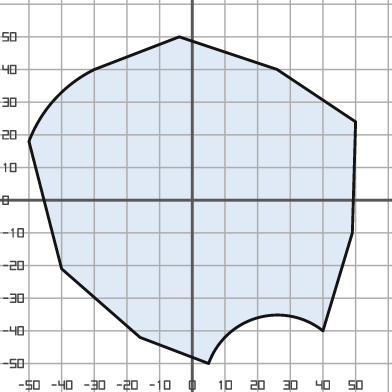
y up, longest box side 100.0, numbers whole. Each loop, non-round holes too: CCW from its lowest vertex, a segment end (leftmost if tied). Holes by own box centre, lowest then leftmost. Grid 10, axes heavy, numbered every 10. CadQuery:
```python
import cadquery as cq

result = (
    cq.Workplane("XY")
    .moveTo(5.0, -50.0)
    .threePointArc((20.0, -36.0), (40.0, -40.0))
    .lineTo(49.0, -10.0)
    .lineTo(50.0, 24.0)
    .lineTo(26.0, 40.0)
    .lineTo(-4.0, 50.0)
    .lineTo(-30.0, 40.0)
    .threePointArc((-42.0, 31.0), (-50.0, 18.0))
    .lineTo(-40.0, -21.0)
    .lineTo(-16.0, -42.0)
    .close()
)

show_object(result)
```